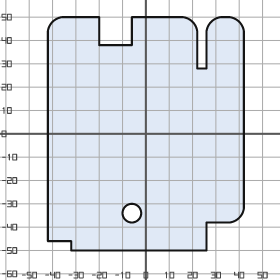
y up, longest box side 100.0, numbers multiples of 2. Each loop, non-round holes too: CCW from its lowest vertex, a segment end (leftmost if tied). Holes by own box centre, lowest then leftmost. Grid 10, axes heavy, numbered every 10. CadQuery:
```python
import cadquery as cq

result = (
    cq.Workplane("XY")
    .moveTo(-32.0, -50.0)
    .lineTo(26.0, -50.0)
    .lineTo(26.0, -38.0)
    .lineTo(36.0, -38.0)
    .threePointArc((40.0, -36.0), (42.0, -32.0))
    .lineTo(42.0, 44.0)
    .threePointArc((40.0, 48.0), (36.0, 50.0))
    .lineTo(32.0, 50.0)
    .threePointArc((28.0, 48.0), (26.0, 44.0))
    .lineTo(26.0, 28.0)
    .lineTo(22.0, 28.0)
    .lineTo(22.0, 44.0)
    .threePointArc((20.0, 48.0), (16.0, 50.0))
    .lineTo(-6.0, 50.0)
    .lineTo(-6.0, 38.0)
    .lineTo(-20.0, 38.0)
    .lineTo(-20.0, 50.0)
    .lineTo(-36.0, 50.0)
    .threePointArc((-40.0, 48.0), (-42.0, 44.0))
    .lineTo(-42.0, -46.0)
    .lineTo(-32.0, -46.0)
    .close()
    .moveTo(-6.0, -34.0)
    .circle(4.0)
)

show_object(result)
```